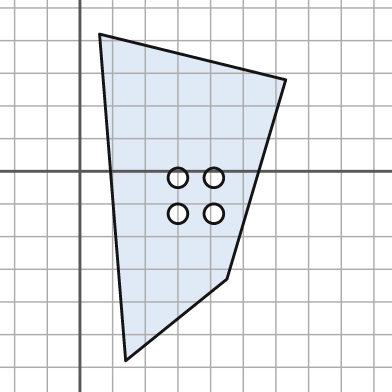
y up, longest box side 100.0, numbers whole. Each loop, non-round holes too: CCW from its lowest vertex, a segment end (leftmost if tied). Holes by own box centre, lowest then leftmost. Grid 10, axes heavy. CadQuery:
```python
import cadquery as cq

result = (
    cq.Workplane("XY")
    .moveTo(14.0, -58.0)
    .lineTo(45.0, -33.0)
    .lineTo(63.0, 28.0)
    .lineTo(6.0, 42.0)
    .close()
    .moveTo(30.0, -13.0)
    .circle(3.0)
    .moveTo(41.0, -13.0)
    .circle(3.0)
    .moveTo(30.0, -2.0)
    .circle(3.0)
    .moveTo(41.0, -2.0)
    .circle(3.0)
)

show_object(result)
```